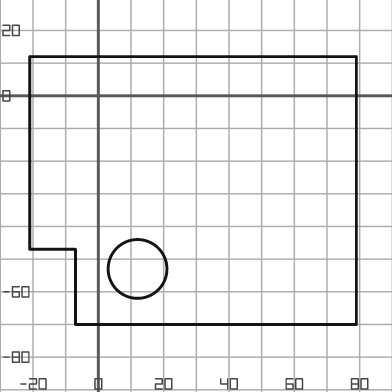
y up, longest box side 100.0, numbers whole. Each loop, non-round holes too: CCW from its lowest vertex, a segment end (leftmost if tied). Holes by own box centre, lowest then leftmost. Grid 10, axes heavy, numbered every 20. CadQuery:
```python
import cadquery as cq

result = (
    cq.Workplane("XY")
    .moveTo(-7.0, -70.0)
    .lineTo(79.0, -70.0)
    .lineTo(79.0, 12.0)
    .lineTo(-21.0, 12.0)
    .lineTo(-21.0, -47.0)
    .lineTo(-7.0, -47.0)
    .close()
    .moveTo(12.0, -53.0)
    .circle(9.0)
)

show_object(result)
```